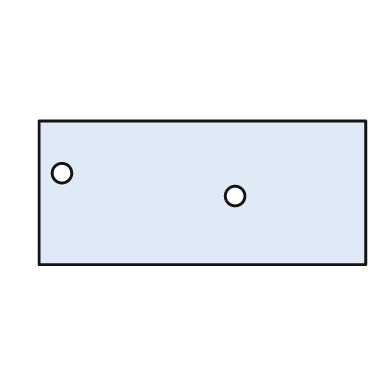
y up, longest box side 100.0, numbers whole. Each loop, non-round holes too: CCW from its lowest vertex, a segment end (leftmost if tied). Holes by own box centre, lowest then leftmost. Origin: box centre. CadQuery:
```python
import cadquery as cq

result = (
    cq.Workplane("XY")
    .moveTo(-50.0, -22.0)
    .lineTo(50.0, -22.0)
    .lineTo(50.0, 22.0)
    .lineTo(-50.0, 22.0)
    .close()
    .moveTo(10.0, -1.0)
    .circle(3.0)
    .moveTo(-43.0, 6.0)
    .circle(3.0)
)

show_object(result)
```